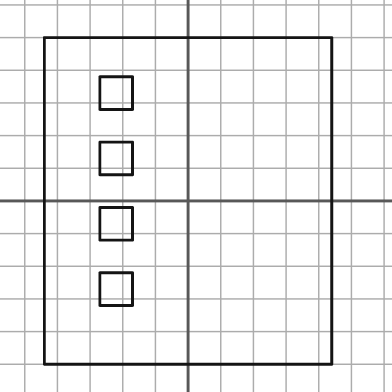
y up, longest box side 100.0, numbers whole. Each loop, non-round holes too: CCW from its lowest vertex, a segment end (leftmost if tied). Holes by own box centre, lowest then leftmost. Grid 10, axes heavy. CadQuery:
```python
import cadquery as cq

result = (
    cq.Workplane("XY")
    .moveTo(-44.0, -50.0)
    .lineTo(44.0, -50.0)
    .lineTo(44.0, 50.0)
    .lineTo(-44.0, 50.0)
    .close()
    .moveTo(-27.0, -32.0)
    .lineTo(-17.0, -32.0)
    .lineTo(-17.0, -22.0)
    .lineTo(-27.0, -22.0)
    .close()
    .moveTo(-27.0, -12.0)
    .lineTo(-17.0, -12.0)
    .lineTo(-17.0, -2.0)
    .lineTo(-27.0, -2.0)
    .close()
    .moveTo(-27.0, 8.0)
    .lineTo(-17.0, 8.0)
    .lineTo(-17.0, 18.0)
    .lineTo(-27.0, 18.0)
    .close()
    .moveTo(-27.0, 28.0)
    .lineTo(-17.0, 28.0)
    .lineTo(-17.0, 38.0)
    .lineTo(-27.0, 38.0)
    .close()
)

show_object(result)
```